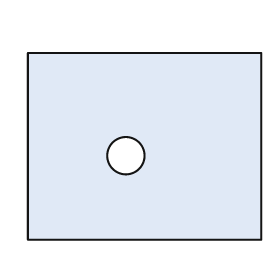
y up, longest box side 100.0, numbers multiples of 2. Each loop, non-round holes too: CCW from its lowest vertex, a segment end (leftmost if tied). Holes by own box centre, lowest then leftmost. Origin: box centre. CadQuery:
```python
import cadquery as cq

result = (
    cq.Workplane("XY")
    .moveTo(-50.0, -40.0)
    .lineTo(50.0, -40.0)
    .lineTo(50.0, 40.0)
    .lineTo(-50.0, 40.0)
    .close()
    .moveTo(-8.0, -4.0)
    .circle(8.0)
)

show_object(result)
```